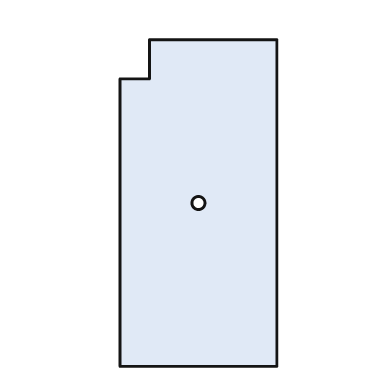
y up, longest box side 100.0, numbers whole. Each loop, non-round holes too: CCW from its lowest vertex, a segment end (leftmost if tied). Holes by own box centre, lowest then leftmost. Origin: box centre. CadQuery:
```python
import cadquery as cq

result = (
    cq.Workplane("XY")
    .moveTo(-24.0, -50.0)
    .lineTo(24.0, -50.0)
    .lineTo(24.0, 50.0)
    .lineTo(-15.0, 50.0)
    .lineTo(-15.0, 38.0)
    .lineTo(-24.0, 38.0)
    .close()
    .moveTo(0.0, 0.0)
    .circle(2.0)
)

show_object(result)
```